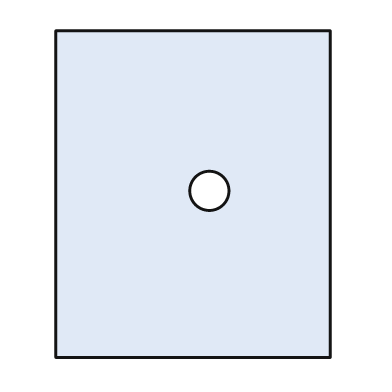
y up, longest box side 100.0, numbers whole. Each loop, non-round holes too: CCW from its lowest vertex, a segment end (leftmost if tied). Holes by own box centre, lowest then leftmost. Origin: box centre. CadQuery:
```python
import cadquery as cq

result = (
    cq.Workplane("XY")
    .moveTo(-42.0, -50.0)
    .lineTo(42.0, -50.0)
    .lineTo(42.0, 50.0)
    .lineTo(-42.0, 50.0)
    .close()
    .moveTo(5.0, 1.0)
    .circle(6.0)
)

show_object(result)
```